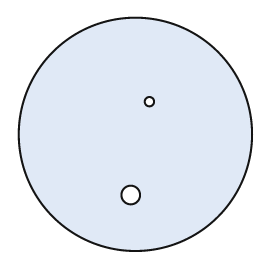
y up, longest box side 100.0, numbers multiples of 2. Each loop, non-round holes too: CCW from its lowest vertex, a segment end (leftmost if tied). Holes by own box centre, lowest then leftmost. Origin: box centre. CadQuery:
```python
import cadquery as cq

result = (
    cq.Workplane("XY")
    .moveTo(0.0, 0.0)
    .circle(50.0)
    .moveTo(-2.0, -26.0)
    .circle(4.0)
    .moveTo(6.0, 14.0)
    .circle(2.0)
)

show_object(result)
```